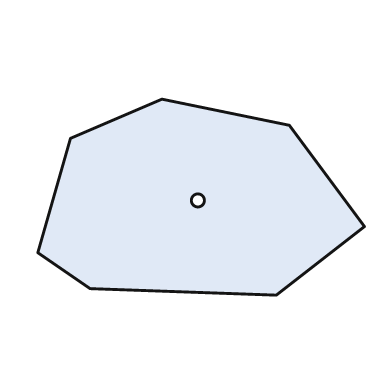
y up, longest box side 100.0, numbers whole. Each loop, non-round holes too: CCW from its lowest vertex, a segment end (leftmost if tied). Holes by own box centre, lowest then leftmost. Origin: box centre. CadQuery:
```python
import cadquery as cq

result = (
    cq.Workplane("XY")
    .moveTo(23.0, -30.0)
    .lineTo(50.0, -9.0)
    .lineTo(27.0, 22.0)
    .lineTo(-12.0, 30.0)
    .lineTo(-40.0, 18.0)
    .lineTo(-50.0, -17.0)
    .lineTo(-34.0, -28.0)
    .close()
    .moveTo(-1.0, -1.0)
    .circle(2.0)
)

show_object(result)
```